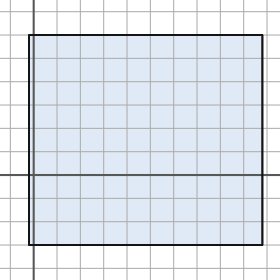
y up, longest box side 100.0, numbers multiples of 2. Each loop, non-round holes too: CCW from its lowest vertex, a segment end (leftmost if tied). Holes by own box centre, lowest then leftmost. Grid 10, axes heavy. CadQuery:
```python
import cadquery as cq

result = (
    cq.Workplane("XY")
    .moveTo(-2.0, -30.0)
    .lineTo(98.0, -30.0)
    .lineTo(98.0, 60.0)
    .lineTo(-2.0, 60.0)
    .close()
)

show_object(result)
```